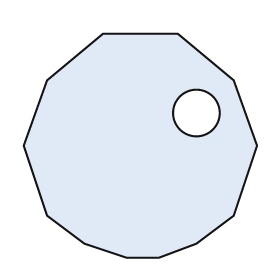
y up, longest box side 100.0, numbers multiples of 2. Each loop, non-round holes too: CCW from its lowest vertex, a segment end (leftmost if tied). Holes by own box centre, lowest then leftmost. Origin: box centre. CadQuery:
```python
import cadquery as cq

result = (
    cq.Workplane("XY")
    .moveTo(-6.0, -48.0)
    .lineTo(8.0, -48.0)
    .lineTo(24.0, -42.0)
    .lineTo(40.0, -30.0)
    .lineTo(50.0, 0.0)
    .lineTo(40.0, 28.0)
    .lineTo(16.0, 48.0)
    .lineTo(-16.0, 48.0)
    .lineTo(-40.0, 28.0)
    .lineTo(-50.0, 0.0)
    .lineTo(-40.0, -30.0)
    .lineTo(-24.0, -42.0)
    .close()
    .moveTo(24.0, 14.0)
    .circle(10.0)
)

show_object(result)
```